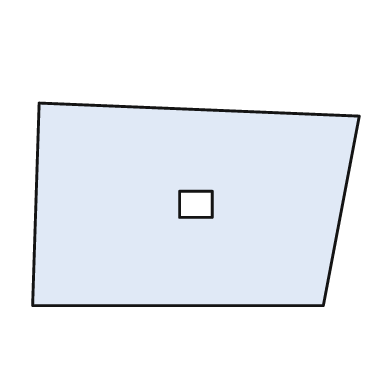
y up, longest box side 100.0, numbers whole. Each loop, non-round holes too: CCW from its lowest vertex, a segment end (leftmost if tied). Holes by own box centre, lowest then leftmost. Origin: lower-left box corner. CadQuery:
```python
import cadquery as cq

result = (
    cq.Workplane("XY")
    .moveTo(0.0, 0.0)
    .lineTo(89.0, 0.0)
    .lineTo(100.0, 58.0)
    .lineTo(2.0, 62.0)
    .close()
    .moveTo(45.0, 27.0)
    .lineTo(55.0, 27.0)
    .lineTo(55.0, 35.0)
    .lineTo(45.0, 35.0)
    .close()
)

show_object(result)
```